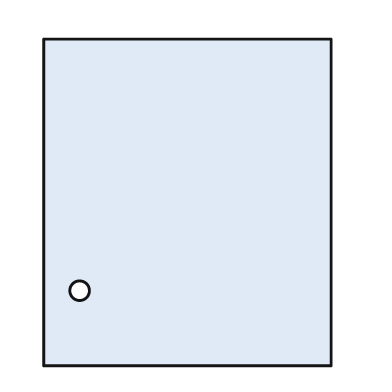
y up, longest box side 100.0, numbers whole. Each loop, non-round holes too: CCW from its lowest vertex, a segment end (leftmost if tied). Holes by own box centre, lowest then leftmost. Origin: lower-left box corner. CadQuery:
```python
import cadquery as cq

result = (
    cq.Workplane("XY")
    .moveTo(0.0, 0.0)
    .lineTo(88.0, 0.0)
    .lineTo(88.0, 100.0)
    .lineTo(0.0, 100.0)
    .close()
    .moveTo(11.0, 23.0)
    .circle(3.0)
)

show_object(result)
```